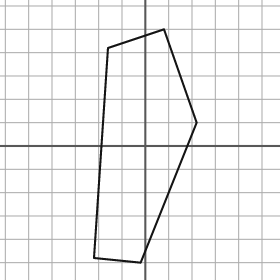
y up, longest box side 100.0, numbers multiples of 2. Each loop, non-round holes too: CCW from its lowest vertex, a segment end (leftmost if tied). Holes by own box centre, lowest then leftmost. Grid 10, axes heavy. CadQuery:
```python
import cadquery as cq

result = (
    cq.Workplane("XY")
    .moveTo(-2.0, -50.0)
    .lineTo(22.0, 10.0)
    .lineTo(8.0, 50.0)
    .lineTo(-16.0, 42.0)
    .lineTo(-22.0, -48.0)
    .close()
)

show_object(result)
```